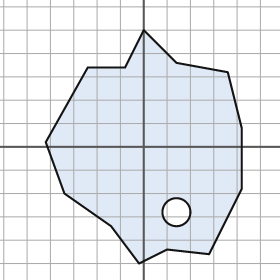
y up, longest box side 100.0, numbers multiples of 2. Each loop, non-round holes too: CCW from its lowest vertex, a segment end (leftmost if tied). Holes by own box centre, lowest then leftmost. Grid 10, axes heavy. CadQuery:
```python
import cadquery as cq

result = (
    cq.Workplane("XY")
    .moveTo(-2.0, -50.0)
    .lineTo(10.0, -44.0)
    .lineTo(28.0, -46.0)
    .lineTo(42.0, -18.0)
    .lineTo(42.0, 8.0)
    .lineTo(36.0, 32.0)
    .lineTo(14.0, 36.0)
    .lineTo(0.0, 50.0)
    .lineTo(-8.0, 34.0)
    .lineTo(-24.0, 34.0)
    .lineTo(-42.0, 2.0)
    .lineTo(-34.0, -20.0)
    .lineTo(-14.0, -34.0)
    .close()
    .moveTo(14.0, -28.0)
    .circle(6.0)
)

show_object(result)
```